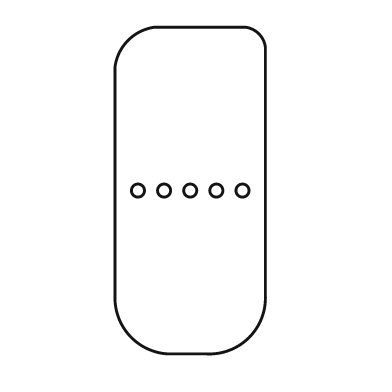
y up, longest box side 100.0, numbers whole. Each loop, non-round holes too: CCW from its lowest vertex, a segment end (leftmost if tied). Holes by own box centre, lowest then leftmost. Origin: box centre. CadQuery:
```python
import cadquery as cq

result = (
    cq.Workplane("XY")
    .moveTo(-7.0, -50.0)
    .lineTo(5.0, -50.0)
    .threePointArc((18.0, -45.0), (23.0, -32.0))
    .lineTo(23.0, 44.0)
    .threePointArc((21.0, 48.0), (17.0, 50.0))
    .lineTo(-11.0, 50.0)
    .threePointArc((-19.0, 46.0), (-23.0, 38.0))
    .lineTo(-23.0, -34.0)
    .threePointArc((-18.0, -45.0), (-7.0, -50.0))
    .close()
    .moveTo(-16.0, 0.0)
    .circle(2.0)
    .moveTo(-8.0, 0.0)
    .circle(2.0)
    .moveTo(0.0, 0.0)
    .circle(2.0)
    .moveTo(8.0, 0.0)
    .circle(2.0)
    .moveTo(16.0, 0.0)
    .circle(2.0)
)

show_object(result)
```